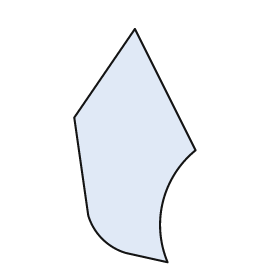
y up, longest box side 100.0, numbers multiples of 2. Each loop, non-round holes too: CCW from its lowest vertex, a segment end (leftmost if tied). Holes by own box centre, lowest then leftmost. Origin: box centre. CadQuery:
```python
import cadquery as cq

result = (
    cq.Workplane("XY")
    .moveTo(14.0, -50.0)
    .threePointArc((12.0, -24.0), (26.0, -2.0))
    .lineTo(0.0, 50.0)
    .lineTo(-26.0, 12.0)
    .lineTo(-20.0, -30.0)
    .threePointArc((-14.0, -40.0), (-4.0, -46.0))
    .close()
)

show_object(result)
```